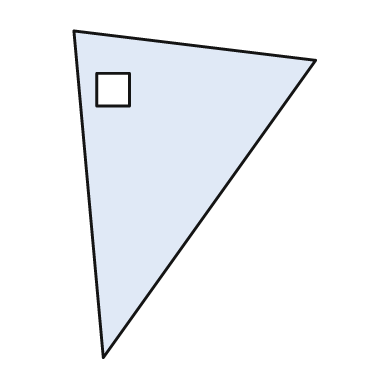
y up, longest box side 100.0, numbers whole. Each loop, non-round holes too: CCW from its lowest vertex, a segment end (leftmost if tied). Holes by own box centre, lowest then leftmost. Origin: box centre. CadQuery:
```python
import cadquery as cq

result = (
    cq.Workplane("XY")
    .moveTo(-28.0, -50.0)
    .lineTo(37.0, 41.0)
    .lineTo(-37.0, 50.0)
    .close()
    .moveTo(-30.0, 27.0)
    .lineTo(-20.0, 27.0)
    .lineTo(-20.0, 37.0)
    .lineTo(-30.0, 37.0)
    .close()
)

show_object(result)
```